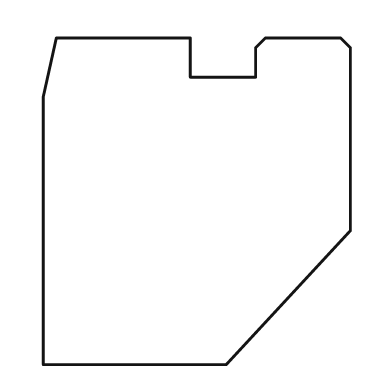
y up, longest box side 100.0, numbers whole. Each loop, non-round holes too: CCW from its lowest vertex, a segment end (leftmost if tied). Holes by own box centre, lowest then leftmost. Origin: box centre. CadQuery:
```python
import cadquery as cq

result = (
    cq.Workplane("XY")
    .moveTo(-47.0, -50.0)
    .lineTo(9.0, -50.0)
    .lineTo(47.0, -9.0)
    .lineTo(47.0, 47.0)
    .lineTo(44.0, 50.0)
    .lineTo(21.0, 50.0)
    .lineTo(18.0, 47.0)
    .lineTo(18.0, 38.0)
    .lineTo(-2.0, 38.0)
    .lineTo(-2.0, 50.0)
    .lineTo(-43.0, 50.0)
    .lineTo(-47.0, 32.0)
    .close()
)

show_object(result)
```